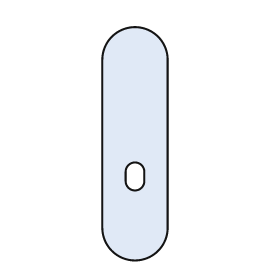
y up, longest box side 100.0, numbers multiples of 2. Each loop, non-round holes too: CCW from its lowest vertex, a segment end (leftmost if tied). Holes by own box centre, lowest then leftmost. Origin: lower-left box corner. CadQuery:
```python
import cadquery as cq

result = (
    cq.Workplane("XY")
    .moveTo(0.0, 14.0)
    .threePointArc((14.0, 0.0), (28.0, 14.0))
    .lineTo(28.0, 86.0)
    .threePointArc((14.0, 100.0), (0.0, 86.0))
    .close()
    .moveTo(10.0, 34.0)
    .threePointArc((14.0, 30.0), (18.0, 34.0))
    .lineTo(18.0, 38.0)
    .threePointArc((14.0, 42.0), (10.0, 38.0))
    .close()
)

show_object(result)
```